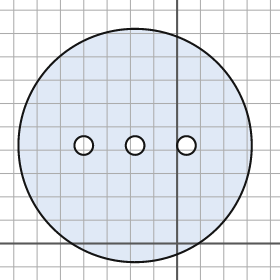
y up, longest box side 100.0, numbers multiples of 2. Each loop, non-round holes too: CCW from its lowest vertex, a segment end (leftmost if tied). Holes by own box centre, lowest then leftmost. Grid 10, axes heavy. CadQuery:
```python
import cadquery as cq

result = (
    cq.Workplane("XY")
    .moveTo(-18.0, 42.0)
    .circle(50.0)
    .moveTo(-40.0, 42.0)
    .circle(4.0)
    .moveTo(-18.0, 42.0)
    .circle(4.0)
    .moveTo(4.0, 42.0)
    .circle(4.0)
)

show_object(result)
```